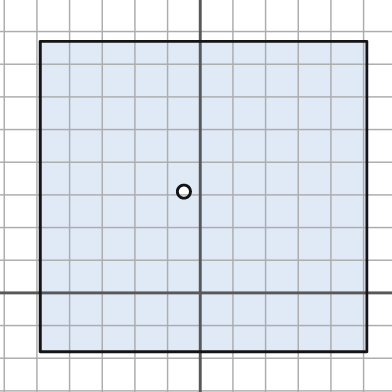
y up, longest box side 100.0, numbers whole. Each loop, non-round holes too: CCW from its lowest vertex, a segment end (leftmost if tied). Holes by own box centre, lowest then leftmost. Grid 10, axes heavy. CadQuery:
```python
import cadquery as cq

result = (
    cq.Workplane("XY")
    .moveTo(-49.0, -18.0)
    .lineTo(51.0, -18.0)
    .lineTo(51.0, 77.0)
    .lineTo(-49.0, 77.0)
    .close()
    .moveTo(-5.0, 31.0)
    .circle(2.0)
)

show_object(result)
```